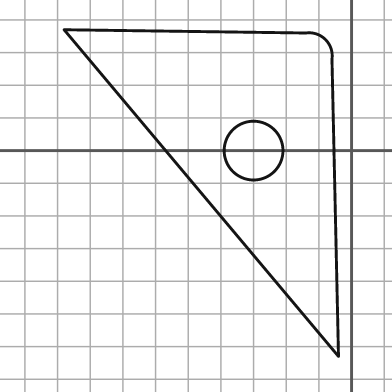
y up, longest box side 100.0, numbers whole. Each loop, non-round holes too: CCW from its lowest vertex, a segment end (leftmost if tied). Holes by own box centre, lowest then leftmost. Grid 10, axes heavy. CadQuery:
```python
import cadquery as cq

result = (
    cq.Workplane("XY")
    .moveTo(-4.0, -63.0)
    .lineTo(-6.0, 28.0)
    .threePointArc((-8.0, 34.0), (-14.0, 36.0))
    .lineTo(-88.0, 37.0)
    .close()
    .moveTo(-30.0, 0.0)
    .circle(9.0)
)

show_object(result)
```